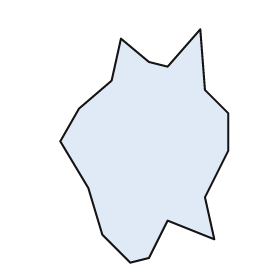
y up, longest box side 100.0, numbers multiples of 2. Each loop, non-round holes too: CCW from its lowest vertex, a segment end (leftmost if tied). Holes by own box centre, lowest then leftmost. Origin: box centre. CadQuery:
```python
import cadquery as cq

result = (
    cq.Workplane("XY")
    .moveTo(-6.0, -50.0)
    .lineTo(2.0, -48.0)
    .lineTo(10.0, -32.0)
    .lineTo(30.0, -40.0)
    .lineTo(26.0, -22.0)
    .lineTo(36.0, -2.0)
    .lineTo(36.0, 14.0)
    .lineTo(26.0, 24.0)
    .lineTo(24.0, 50.0)
    .lineTo(10.0, 34.0)
    .lineTo(2.0, 36.0)
    .lineTo(-10.0, 46.0)
    .lineTo(-14.0, 28.0)
    .lineTo(-28.0, 16.0)
    .lineTo(-36.0, 2.0)
    .lineTo(-24.0, -18.0)
    .lineTo(-18.0, -38.0)
    .close()
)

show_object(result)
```